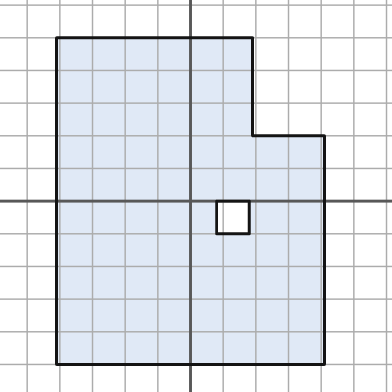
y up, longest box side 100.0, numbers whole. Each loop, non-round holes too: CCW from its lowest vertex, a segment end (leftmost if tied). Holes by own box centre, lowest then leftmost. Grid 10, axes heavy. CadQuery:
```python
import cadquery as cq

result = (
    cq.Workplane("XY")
    .moveTo(-41.0, -50.0)
    .lineTo(41.0, -50.0)
    .lineTo(41.0, 20.0)
    .lineTo(19.0, 20.0)
    .lineTo(19.0, 50.0)
    .lineTo(-41.0, 50.0)
    .close()
    .moveTo(8.0, -10.0)
    .lineTo(18.0, -10.0)
    .lineTo(18.0, 0.0)
    .lineTo(8.0, 0.0)
    .close()
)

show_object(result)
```